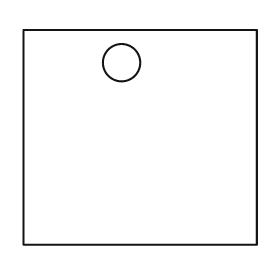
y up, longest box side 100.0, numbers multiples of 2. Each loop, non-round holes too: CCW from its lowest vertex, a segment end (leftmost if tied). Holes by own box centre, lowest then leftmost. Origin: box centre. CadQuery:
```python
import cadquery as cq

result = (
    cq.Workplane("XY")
    .moveTo(-50.0, -46.0)
    .lineTo(50.0, -46.0)
    .lineTo(50.0, 46.0)
    .lineTo(-50.0, 46.0)
    .close()
    .moveTo(-8.0, 32.0)
    .circle(8.0)
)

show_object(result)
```